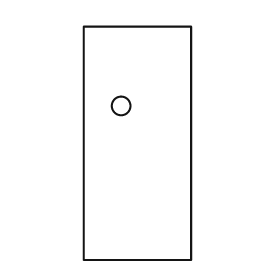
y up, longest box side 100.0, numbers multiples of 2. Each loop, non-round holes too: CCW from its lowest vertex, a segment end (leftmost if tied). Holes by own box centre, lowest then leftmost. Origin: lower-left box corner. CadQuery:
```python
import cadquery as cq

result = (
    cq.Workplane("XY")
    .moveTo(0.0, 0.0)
    .lineTo(46.0, 0.0)
    .lineTo(46.0, 100.0)
    .lineTo(0.0, 100.0)
    .close()
    .moveTo(16.0, 66.0)
    .circle(4.0)
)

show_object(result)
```